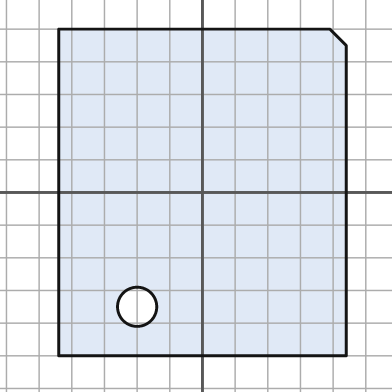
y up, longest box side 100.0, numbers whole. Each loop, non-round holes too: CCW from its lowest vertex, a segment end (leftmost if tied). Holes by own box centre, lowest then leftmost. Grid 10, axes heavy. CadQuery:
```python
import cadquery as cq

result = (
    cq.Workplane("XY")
    .moveTo(-44.0, -50.0)
    .lineTo(44.0, -50.0)
    .lineTo(44.0, 45.0)
    .lineTo(39.0, 50.0)
    .lineTo(-44.0, 50.0)
    .close()
    .moveTo(-20.0, -35.0)
    .circle(6.0)
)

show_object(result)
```